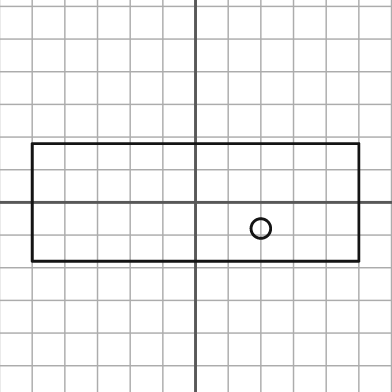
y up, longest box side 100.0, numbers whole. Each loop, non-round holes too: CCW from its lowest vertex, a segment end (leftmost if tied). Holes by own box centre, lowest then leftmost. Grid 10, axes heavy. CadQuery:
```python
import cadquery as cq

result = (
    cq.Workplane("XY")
    .moveTo(-50.0, -18.0)
    .lineTo(50.0, -18.0)
    .lineTo(50.0, 18.0)
    .lineTo(-50.0, 18.0)
    .close()
    .moveTo(20.0, -8.0)
    .circle(3.0)
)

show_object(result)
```